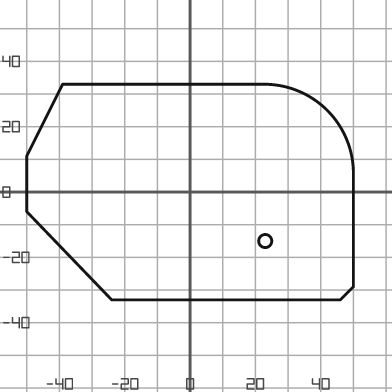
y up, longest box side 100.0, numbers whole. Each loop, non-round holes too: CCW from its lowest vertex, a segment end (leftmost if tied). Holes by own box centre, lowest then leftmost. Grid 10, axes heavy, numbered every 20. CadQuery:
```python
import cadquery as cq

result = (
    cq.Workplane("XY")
    .moveTo(-24.0, -33.0)
    .lineTo(46.0, -33.0)
    .lineTo(50.0, -29.0)
    .lineTo(50.0, 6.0)
    .threePointArc((42.0, 25.0), (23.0, 33.0))
    .lineTo(-39.0, 33.0)
    .lineTo(-50.0, 11.0)
    .lineTo(-50.0, -6.0)
    .close()
    .moveTo(23.0, -15.0)
    .circle(2.0)
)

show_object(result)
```